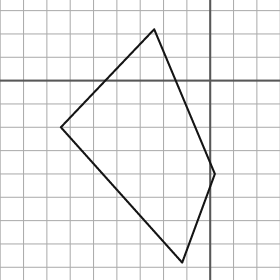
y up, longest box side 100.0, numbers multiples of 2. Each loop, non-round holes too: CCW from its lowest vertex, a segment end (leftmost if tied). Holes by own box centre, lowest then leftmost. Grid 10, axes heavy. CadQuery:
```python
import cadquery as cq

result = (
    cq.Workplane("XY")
    .moveTo(-12.0, -78.0)
    .lineTo(2.0, -40.0)
    .lineTo(-24.0, 22.0)
    .lineTo(-64.0, -20.0)
    .close()
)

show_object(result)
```